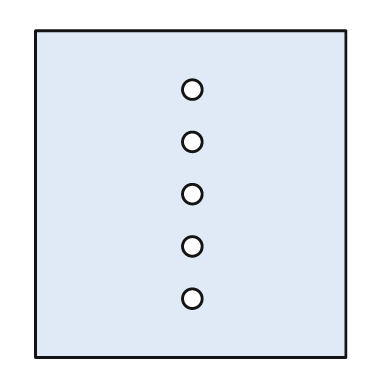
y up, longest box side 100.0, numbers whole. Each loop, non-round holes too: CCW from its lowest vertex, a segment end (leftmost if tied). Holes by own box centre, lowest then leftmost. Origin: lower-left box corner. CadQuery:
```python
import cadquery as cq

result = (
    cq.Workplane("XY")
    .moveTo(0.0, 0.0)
    .lineTo(95.0, 0.0)
    .lineTo(95.0, 100.0)
    .lineTo(0.0, 100.0)
    .close()
    .moveTo(48.0, 18.0)
    .circle(3.0)
    .moveTo(48.0, 34.0)
    .circle(3.0)
    .moveTo(48.0, 50.0)
    .circle(3.0)
    .moveTo(48.0, 66.0)
    .circle(3.0)
    .moveTo(48.0, 82.0)
    .circle(3.0)
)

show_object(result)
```